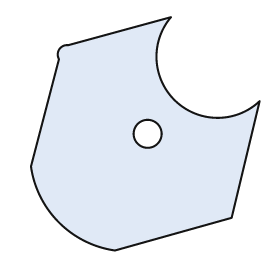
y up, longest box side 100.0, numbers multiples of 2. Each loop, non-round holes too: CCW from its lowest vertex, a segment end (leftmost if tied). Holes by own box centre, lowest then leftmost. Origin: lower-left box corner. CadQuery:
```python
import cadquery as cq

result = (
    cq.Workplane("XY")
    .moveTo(36.0, 0.0)
    .lineTo(86.0, 14.0)
    .lineTo(98.0, 64.0)
    .threePointArc((62.0, 64.0), (60.0, 100.0))
    .lineTo(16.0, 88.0)
    .threePointArc((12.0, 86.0), (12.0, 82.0))
    .lineTo(0.0, 36.0)
    .threePointArc((12.0, 12.0), (36.0, 0.0))
    .close()
    .moveTo(50.0, 50.0)
    .circle(6.0)
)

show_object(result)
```